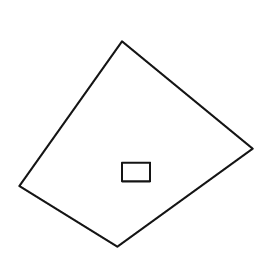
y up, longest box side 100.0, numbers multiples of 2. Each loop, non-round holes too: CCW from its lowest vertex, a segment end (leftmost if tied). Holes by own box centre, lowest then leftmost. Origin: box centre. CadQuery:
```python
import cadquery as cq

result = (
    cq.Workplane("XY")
    .moveTo(-8.0, -44.0)
    .lineTo(50.0, -2.0)
    .lineTo(-6.0, 44.0)
    .lineTo(-50.0, -18.0)
    .close()
    .moveTo(-6.0, -16.0)
    .lineTo(6.0, -16.0)
    .lineTo(6.0, -8.0)
    .lineTo(-6.0, -8.0)
    .close()
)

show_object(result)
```